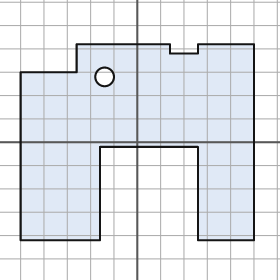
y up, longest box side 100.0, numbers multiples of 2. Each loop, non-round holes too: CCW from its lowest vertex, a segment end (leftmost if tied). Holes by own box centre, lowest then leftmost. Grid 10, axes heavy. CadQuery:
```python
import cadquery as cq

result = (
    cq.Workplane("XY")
    .moveTo(-50.0, -42.0)
    .lineTo(-16.0, -42.0)
    .lineTo(-16.0, -2.0)
    .lineTo(26.0, -2.0)
    .lineTo(26.0, -42.0)
    .lineTo(50.0, -42.0)
    .lineTo(50.0, 42.0)
    .lineTo(26.0, 42.0)
    .lineTo(26.0, 38.0)
    .lineTo(14.0, 38.0)
    .lineTo(14.0, 42.0)
    .lineTo(-26.0, 42.0)
    .lineTo(-26.0, 30.0)
    .lineTo(-50.0, 30.0)
    .close()
    .moveTo(-14.0, 28.0)
    .circle(4.0)
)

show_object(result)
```